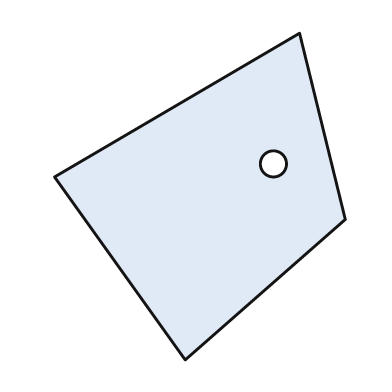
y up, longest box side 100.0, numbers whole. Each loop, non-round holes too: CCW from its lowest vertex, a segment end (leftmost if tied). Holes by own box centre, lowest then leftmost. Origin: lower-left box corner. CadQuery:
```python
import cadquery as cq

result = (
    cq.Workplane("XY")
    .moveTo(40.0, 0.0)
    .lineTo(89.0, 43.0)
    .lineTo(75.0, 100.0)
    .lineTo(0.0, 56.0)
    .close()
    .moveTo(67.0, 60.0)
    .circle(4.0)
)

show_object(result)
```